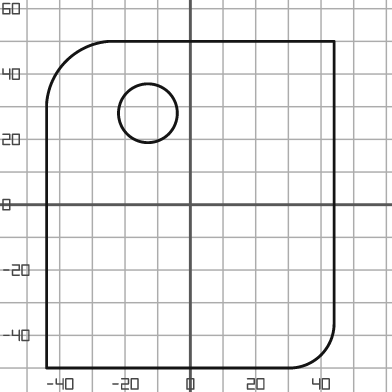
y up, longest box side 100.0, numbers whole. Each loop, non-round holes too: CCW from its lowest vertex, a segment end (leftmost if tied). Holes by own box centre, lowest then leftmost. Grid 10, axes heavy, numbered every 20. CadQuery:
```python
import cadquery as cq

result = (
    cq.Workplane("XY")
    .moveTo(-44.0, -50.0)
    .lineTo(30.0, -50.0)
    .threePointArc((40.0, -46.0), (44.0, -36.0))
    .lineTo(44.0, 50.0)
    .lineTo(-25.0, 50.0)
    .threePointArc((-38.0, 44.0), (-44.0, 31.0))
    .close()
    .moveTo(-13.0, 28.0)
    .circle(9.0)
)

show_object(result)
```